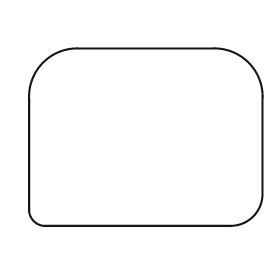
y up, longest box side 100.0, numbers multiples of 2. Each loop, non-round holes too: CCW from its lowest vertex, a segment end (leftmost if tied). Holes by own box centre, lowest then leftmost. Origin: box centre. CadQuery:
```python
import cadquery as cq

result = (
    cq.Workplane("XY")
    .moveTo(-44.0, -38.0)
    .lineTo(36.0, -38.0)
    .threePointArc((46.0, -34.0), (50.0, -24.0))
    .lineTo(50.0, 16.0)
    .threePointArc((44.0, 32.0), (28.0, 38.0))
    .lineTo(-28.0, 38.0)
    .threePointArc((-44.0, 32.0), (-50.0, 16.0))
    .lineTo(-50.0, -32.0)
    .threePointArc((-48.0, -36.0), (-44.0, -38.0))
    .close()
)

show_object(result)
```